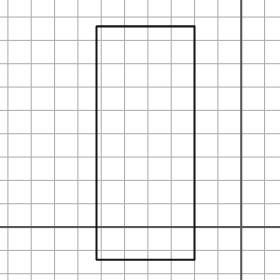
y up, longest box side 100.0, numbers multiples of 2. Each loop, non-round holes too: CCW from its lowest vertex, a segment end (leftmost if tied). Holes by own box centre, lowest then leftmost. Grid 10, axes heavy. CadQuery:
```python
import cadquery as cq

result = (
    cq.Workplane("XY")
    .moveTo(-62.0, -14.0)
    .lineTo(-20.0, -14.0)
    .lineTo(-20.0, 86.0)
    .lineTo(-62.0, 86.0)
    .close()
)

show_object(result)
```